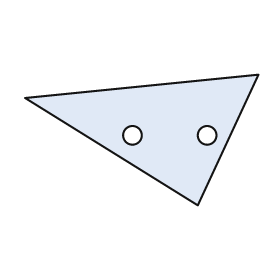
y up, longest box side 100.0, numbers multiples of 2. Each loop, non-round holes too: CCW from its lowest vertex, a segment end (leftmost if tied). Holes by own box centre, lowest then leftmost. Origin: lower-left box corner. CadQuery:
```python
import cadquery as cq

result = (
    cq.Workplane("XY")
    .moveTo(74.0, 0.0)
    .lineTo(100.0, 56.0)
    .lineTo(0.0, 46.0)
    .close()
    .moveTo(46.0, 30.0)
    .circle(4.0)
    .moveTo(78.0, 30.0)
    .circle(4.0)
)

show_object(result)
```